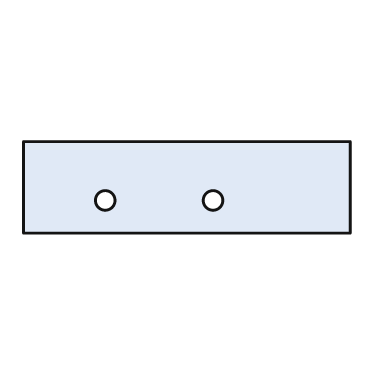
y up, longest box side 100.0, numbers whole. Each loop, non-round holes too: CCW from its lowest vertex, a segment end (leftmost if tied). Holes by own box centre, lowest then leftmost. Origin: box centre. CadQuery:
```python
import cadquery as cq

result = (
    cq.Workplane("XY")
    .moveTo(-50.0, -14.0)
    .lineTo(50.0, -14.0)
    .lineTo(50.0, 14.0)
    .lineTo(-50.0, 14.0)
    .close()
    .moveTo(-25.0, -4.0)
    .circle(3.0)
    .moveTo(8.0, -4.0)
    .circle(3.0)
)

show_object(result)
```